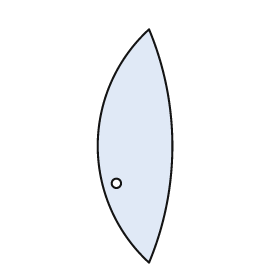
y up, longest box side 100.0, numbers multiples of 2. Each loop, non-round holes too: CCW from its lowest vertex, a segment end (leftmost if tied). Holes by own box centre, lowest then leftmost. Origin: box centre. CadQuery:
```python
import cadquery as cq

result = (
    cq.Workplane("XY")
    .moveTo(6.0, -50.0)
    .threePointArc((16.0, 0.0), (6.0, 50.0))
    .threePointArc((-16.0, 0.0), (6.0, -50.0))
    .close()
    .moveTo(-8.0, -16.0)
    .circle(2.0)
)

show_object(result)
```